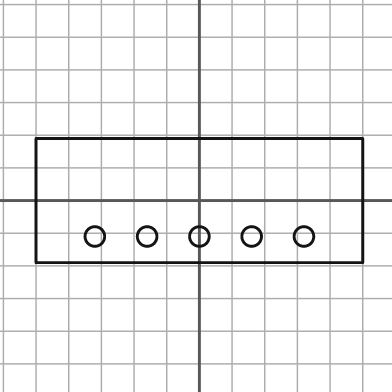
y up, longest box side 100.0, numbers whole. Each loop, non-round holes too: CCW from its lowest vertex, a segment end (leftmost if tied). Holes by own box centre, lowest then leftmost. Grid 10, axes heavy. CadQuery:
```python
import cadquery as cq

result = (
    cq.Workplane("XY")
    .moveTo(-50.0, -19.0)
    .lineTo(50.0, -19.0)
    .lineTo(50.0, 19.0)
    .lineTo(-50.0, 19.0)
    .close()
    .moveTo(-32.0, -11.0)
    .circle(3.0)
    .moveTo(-16.0, -11.0)
    .circle(3.0)
    .moveTo(0.0, -11.0)
    .circle(3.0)
    .moveTo(16.0, -11.0)
    .circle(3.0)
    .moveTo(32.0, -11.0)
    .circle(3.0)
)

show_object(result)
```